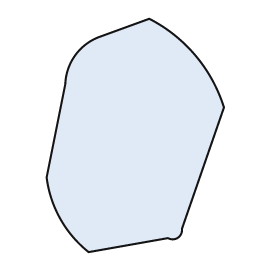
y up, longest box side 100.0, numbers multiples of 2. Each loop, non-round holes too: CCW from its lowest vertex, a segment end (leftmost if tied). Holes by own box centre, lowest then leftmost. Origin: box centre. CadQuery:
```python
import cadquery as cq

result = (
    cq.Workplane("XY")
    .moveTo(-20.0, -50.0)
    .lineTo(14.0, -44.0)
    .threePointArc((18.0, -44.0), (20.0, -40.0))
    .lineTo(38.0, 12.0)
    .threePointArc((26.0, 34.0), (6.0, 50.0))
    .lineTo(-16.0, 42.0)
    .threePointArc((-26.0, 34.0), (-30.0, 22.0))
    .lineTo(-38.0, -18.0)
    .threePointArc((-32.0, -36.0), (-20.0, -50.0))
    .close()
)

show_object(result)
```